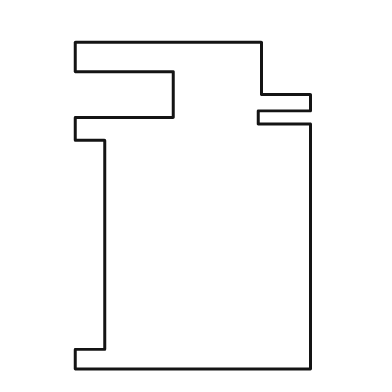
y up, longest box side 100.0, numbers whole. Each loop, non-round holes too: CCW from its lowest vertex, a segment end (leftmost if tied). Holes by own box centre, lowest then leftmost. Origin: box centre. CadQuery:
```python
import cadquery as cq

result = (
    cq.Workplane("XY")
    .moveTo(-36.0, -50.0)
    .lineTo(36.0, -50.0)
    .lineTo(36.0, 25.0)
    .lineTo(20.0, 25.0)
    .lineTo(20.0, 29.0)
    .lineTo(36.0, 29.0)
    .lineTo(36.0, 34.0)
    .lineTo(21.0, 34.0)
    .lineTo(21.0, 50.0)
    .lineTo(-36.0, 50.0)
    .lineTo(-36.0, 41.0)
    .lineTo(-6.0, 41.0)
    .lineTo(-6.0, 27.0)
    .lineTo(-36.0, 27.0)
    .lineTo(-36.0, 20.0)
    .lineTo(-27.0, 20.0)
    .lineTo(-27.0, -44.0)
    .lineTo(-36.0, -44.0)
    .close()
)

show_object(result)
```